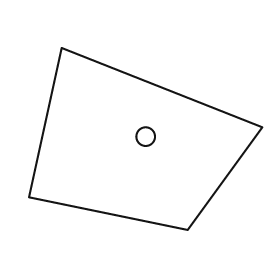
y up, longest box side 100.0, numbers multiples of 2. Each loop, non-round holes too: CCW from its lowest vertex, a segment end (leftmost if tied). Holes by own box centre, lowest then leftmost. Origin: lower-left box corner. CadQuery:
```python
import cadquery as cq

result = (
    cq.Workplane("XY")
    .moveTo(68.0, 0.0)
    .lineTo(100.0, 44.0)
    .lineTo(14.0, 78.0)
    .lineTo(0.0, 14.0)
    .close()
    .moveTo(50.0, 40.0)
    .circle(4.0)
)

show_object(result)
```